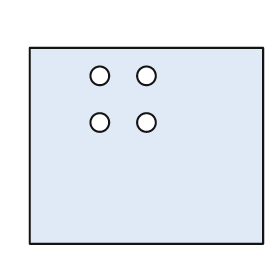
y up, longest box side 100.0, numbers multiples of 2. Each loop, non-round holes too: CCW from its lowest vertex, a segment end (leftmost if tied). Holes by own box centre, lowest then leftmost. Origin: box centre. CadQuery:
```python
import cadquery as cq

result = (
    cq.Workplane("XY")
    .moveTo(-50.0, -42.0)
    .lineTo(50.0, -42.0)
    .lineTo(50.0, 42.0)
    .lineTo(-50.0, 42.0)
    .close()
    .moveTo(-20.0, 10.0)
    .circle(4.0)
    .moveTo(0.0, 10.0)
    .circle(4.0)
    .moveTo(-20.0, 30.0)
    .circle(4.0)
    .moveTo(0.0, 30.0)
    .circle(4.0)
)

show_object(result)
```